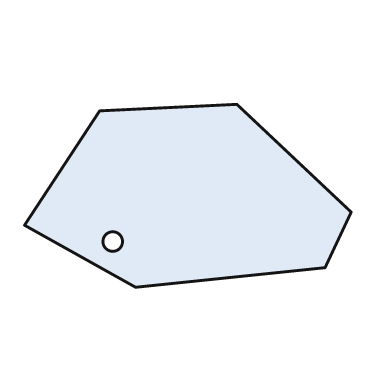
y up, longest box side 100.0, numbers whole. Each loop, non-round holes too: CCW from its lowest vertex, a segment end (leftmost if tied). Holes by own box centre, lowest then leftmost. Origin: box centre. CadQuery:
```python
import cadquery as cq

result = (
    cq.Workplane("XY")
    .moveTo(-16.0, -28.0)
    .lineTo(42.0, -22.0)
    .lineTo(50.0, -5.0)
    .lineTo(15.0, 28.0)
    .lineTo(-27.0, 26.0)
    .lineTo(-50.0, -9.0)
    .close()
    .moveTo(-23.0, -14.0)
    .circle(3.0)
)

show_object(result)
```